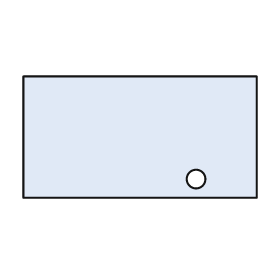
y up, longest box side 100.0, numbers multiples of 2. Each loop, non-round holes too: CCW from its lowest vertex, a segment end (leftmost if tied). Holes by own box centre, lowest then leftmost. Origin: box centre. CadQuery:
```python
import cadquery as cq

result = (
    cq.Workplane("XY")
    .moveTo(-50.0, -26.0)
    .lineTo(50.0, -26.0)
    .lineTo(50.0, 26.0)
    .lineTo(-50.0, 26.0)
    .close()
    .moveTo(24.0, -18.0)
    .circle(4.0)
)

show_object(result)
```